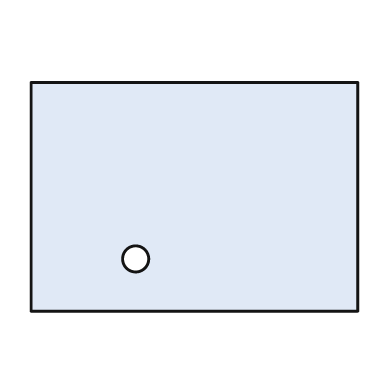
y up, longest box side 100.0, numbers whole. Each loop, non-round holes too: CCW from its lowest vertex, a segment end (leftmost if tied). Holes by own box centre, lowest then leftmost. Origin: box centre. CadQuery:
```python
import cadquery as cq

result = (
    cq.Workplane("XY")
    .moveTo(-50.0, -35.0)
    .lineTo(50.0, -35.0)
    .lineTo(50.0, 35.0)
    .lineTo(-50.0, 35.0)
    .close()
    .moveTo(-18.0, -19.0)
    .circle(4.0)
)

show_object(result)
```